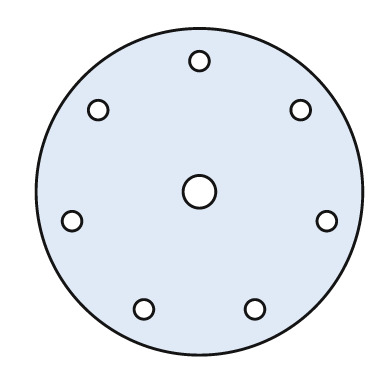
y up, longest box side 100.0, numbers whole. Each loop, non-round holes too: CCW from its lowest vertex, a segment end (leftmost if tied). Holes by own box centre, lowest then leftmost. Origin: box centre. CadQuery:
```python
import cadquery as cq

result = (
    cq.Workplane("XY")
    .moveTo(0.0, 0.0)
    .circle(50.0)
    .moveTo(-17.0, -36.0)
    .circle(3.0)
    .moveTo(17.0, -36.0)
    .circle(3.0)
    .moveTo(-39.0, -9.0)
    .circle(3.0)
    .moveTo(39.0, -9.0)
    .circle(3.0)
    .moveTo(0.0, 0.0)
    .circle(5.0)
    .moveTo(-31.0, 25.0)
    .circle(3.0)
    .moveTo(31.0, 25.0)
    .circle(3.0)
    .moveTo(0.0, 40.0)
    .circle(3.0)
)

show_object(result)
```